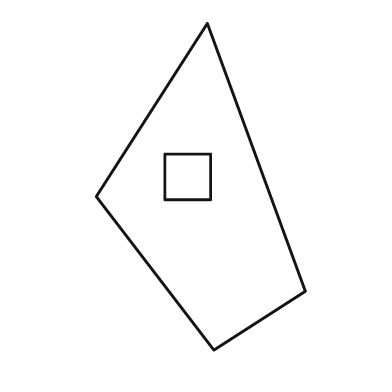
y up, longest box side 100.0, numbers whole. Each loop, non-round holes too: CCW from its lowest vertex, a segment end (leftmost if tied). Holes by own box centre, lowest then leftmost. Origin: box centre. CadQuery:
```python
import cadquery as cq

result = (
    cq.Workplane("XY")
    .moveTo(4.0, -50.0)
    .lineTo(32.0, -32.0)
    .lineTo(2.0, 50.0)
    .lineTo(-32.0, -3.0)
    .close()
    .moveTo(-11.0, -4.0)
    .lineTo(3.0, -4.0)
    .lineTo(3.0, 10.0)
    .lineTo(-11.0, 10.0)
    .close()
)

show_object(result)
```